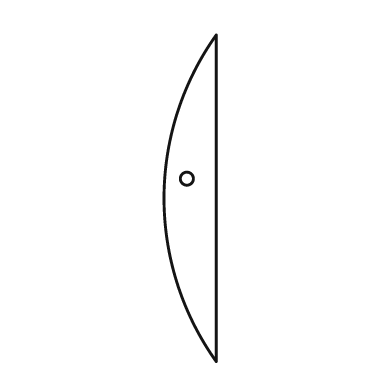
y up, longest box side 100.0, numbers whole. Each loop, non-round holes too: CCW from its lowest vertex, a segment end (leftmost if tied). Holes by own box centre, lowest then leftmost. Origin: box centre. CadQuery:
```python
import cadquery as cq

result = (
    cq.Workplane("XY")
    .moveTo(8.0, -50.0)
    .lineTo(8.0, 50.0)
    .threePointArc((-8.0, 0.0), (8.0, -50.0))
    .close()
    .moveTo(-1.0, 6.0)
    .circle(2.0)
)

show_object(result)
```